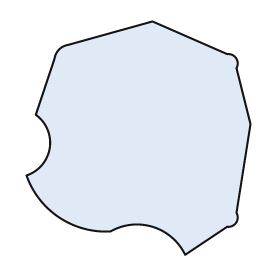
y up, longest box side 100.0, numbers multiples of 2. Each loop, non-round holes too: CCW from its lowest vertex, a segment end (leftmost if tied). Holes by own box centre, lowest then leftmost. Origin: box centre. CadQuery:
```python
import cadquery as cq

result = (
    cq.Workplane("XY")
    .moveTo(20.0, -50.0)
    .lineTo(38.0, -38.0)
    .threePointArc((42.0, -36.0), (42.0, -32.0))
    .lineTo(48.0, 6.0)
    .lineTo(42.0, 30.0)
    .threePointArc((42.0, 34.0), (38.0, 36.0))
    .lineTo(6.0, 50.0)
    .lineTo(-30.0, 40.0)
    .threePointArc((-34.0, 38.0), (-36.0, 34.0))
    .lineTo(-44.0, 10.0)
    .threePointArc((-38.0, -4.0), (-48.0, -16.0))
    .threePointArc((-34.0, -34.0), (-12.0, -40.0))
    .threePointArc((6.0, -38.0), (20.0, -50.0))
    .close()
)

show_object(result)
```